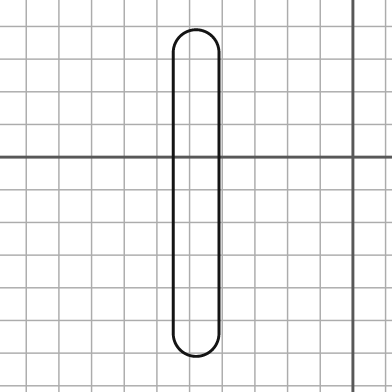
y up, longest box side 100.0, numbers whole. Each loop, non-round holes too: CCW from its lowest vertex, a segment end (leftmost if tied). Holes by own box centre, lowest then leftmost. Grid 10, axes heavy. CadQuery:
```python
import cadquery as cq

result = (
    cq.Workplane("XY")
    .moveTo(-55.0, -54.0)
    .threePointArc((-48.0, -61.0), (-41.0, -54.0))
    .lineTo(-41.0, 32.0)
    .threePointArc((-48.0, 39.0), (-55.0, 32.0))
    .close()
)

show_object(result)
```